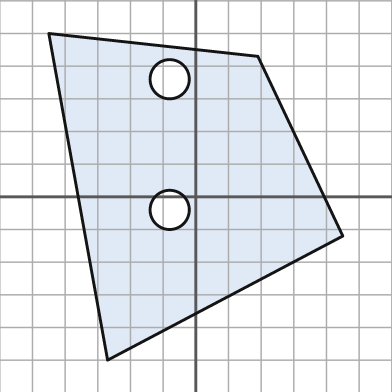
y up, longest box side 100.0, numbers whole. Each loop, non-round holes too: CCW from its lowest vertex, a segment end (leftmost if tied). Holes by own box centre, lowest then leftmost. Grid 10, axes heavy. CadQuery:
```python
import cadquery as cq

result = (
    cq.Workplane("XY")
    .moveTo(-27.0, -50.0)
    .lineTo(45.0, -12.0)
    .lineTo(19.0, 43.0)
    .lineTo(-45.0, 50.0)
    .close()
    .moveTo(-8.0, -4.0)
    .circle(6.0)
    .moveTo(-8.0, 36.0)
    .circle(6.0)
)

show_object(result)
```